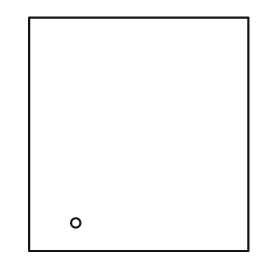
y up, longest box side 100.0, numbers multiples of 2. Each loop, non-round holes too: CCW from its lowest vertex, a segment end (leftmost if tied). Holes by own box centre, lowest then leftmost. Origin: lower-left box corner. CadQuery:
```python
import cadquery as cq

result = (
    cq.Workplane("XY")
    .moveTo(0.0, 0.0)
    .lineTo(94.0, 0.0)
    .lineTo(94.0, 100.0)
    .lineTo(0.0, 100.0)
    .close()
    .moveTo(20.0, 12.0)
    .circle(2.0)
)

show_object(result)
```